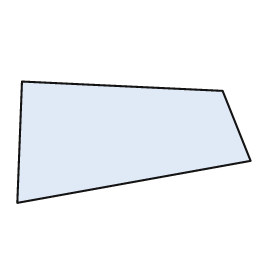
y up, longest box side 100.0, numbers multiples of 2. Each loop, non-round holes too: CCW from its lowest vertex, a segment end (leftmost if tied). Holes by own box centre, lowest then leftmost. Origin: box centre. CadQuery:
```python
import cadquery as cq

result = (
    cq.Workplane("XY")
    .moveTo(-50.0, -26.0)
    .lineTo(50.0, -8.0)
    .lineTo(38.0, 22.0)
    .lineTo(-48.0, 26.0)
    .close()
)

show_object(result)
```